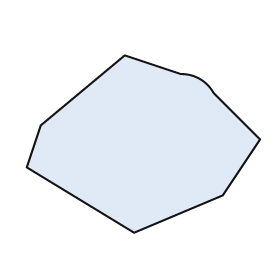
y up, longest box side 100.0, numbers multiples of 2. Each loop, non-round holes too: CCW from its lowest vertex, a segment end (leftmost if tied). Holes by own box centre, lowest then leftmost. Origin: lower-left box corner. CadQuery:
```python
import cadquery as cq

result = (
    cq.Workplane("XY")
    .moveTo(46.0, 0.0)
    .lineTo(84.0, 16.0)
    .lineTo(100.0, 40.0)
    .lineTo(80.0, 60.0)
    .threePointArc((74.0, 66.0), (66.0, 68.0))
    .lineTo(42.0, 76.0)
    .lineTo(6.0, 46.0)
    .lineTo(0.0, 28.0)
    .close()
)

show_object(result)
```